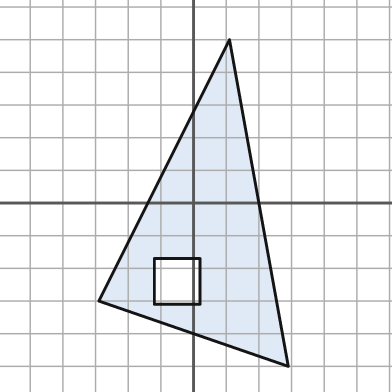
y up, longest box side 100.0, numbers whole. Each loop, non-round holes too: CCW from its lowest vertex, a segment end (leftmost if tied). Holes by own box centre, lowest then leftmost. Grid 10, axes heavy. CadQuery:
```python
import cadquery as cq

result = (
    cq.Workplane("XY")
    .moveTo(29.0, -50.0)
    .lineTo(11.0, 50.0)
    .lineTo(-29.0, -30.0)
    .close()
    .moveTo(-12.0, -31.0)
    .lineTo(2.0, -31.0)
    .lineTo(2.0, -17.0)
    .lineTo(-12.0, -17.0)
    .close()
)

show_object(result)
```